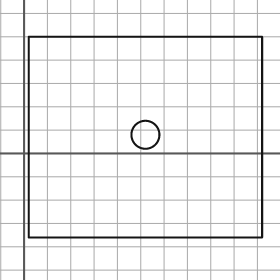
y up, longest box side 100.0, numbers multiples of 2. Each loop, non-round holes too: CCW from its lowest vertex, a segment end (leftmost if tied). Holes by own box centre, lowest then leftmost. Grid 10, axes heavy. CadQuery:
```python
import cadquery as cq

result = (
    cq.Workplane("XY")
    .moveTo(2.0, -36.0)
    .lineTo(102.0, -36.0)
    .lineTo(102.0, 50.0)
    .lineTo(2.0, 50.0)
    .close()
    .moveTo(52.0, 8.0)
    .circle(6.0)
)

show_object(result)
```